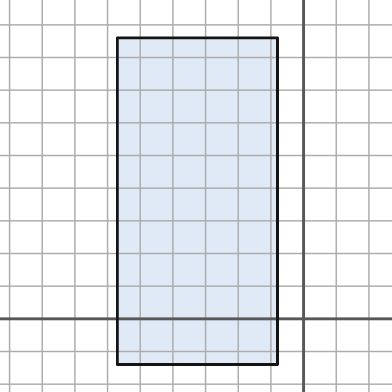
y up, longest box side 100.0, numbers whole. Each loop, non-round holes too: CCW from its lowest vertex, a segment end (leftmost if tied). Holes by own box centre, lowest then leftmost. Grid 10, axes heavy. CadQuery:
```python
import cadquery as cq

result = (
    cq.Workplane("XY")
    .moveTo(-57.0, -14.0)
    .lineTo(-8.0, -14.0)
    .lineTo(-8.0, 86.0)
    .lineTo(-57.0, 86.0)
    .close()
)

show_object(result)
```